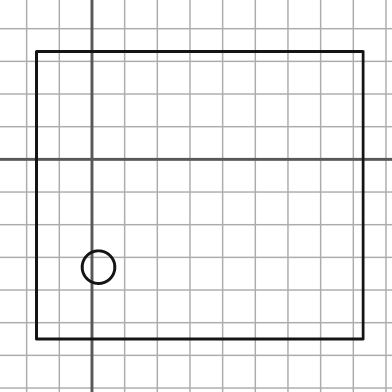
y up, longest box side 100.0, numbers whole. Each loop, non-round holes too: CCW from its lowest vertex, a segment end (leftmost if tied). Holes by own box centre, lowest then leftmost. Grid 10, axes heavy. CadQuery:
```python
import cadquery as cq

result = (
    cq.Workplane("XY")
    .moveTo(-17.0, -55.0)
    .lineTo(83.0, -55.0)
    .lineTo(83.0, 33.0)
    .lineTo(-17.0, 33.0)
    .close()
    .moveTo(2.0, -33.0)
    .circle(5.0)
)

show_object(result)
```